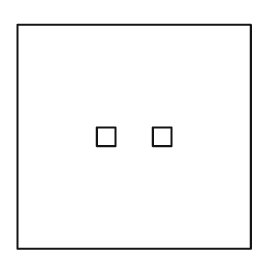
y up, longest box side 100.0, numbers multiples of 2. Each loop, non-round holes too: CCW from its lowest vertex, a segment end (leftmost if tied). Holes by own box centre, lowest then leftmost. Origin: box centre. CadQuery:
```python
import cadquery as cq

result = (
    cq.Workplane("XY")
    .moveTo(-50.0, -48.0)
    .lineTo(50.0, -48.0)
    .lineTo(50.0, 48.0)
    .lineTo(-50.0, 48.0)
    .close()
    .moveTo(-16.0, -4.0)
    .lineTo(-8.0, -4.0)
    .lineTo(-8.0, 4.0)
    .lineTo(-16.0, 4.0)
    .close()
    .moveTo(8.0, -4.0)
    .lineTo(16.0, -4.0)
    .lineTo(16.0, 4.0)
    .lineTo(8.0, 4.0)
    .close()
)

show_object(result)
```